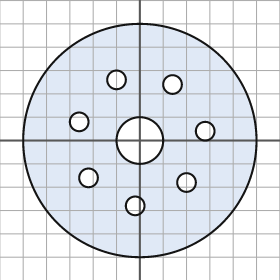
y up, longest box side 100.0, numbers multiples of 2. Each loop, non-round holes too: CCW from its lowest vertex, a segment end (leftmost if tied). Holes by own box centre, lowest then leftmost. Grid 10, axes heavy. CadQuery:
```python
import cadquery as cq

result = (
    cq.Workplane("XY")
    .moveTo(0.0, 0.0)
    .circle(50.0)
    .moveTo(-2.0, -28.0)
    .circle(4.0)
    .moveTo(20.0, -18.0)
    .circle(4.0)
    .moveTo(-22.0, -16.0)
    .circle(4.0)
    .moveTo(0.0, 0.0)
    .circle(10.0)
    .moveTo(28.0, 4.0)
    .circle(4.0)
    .moveTo(-26.0, 8.0)
    .circle(4.0)
    .moveTo(14.0, 24.0)
    .circle(4.0)
    .moveTo(-10.0, 26.0)
    .circle(4.0)
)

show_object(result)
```